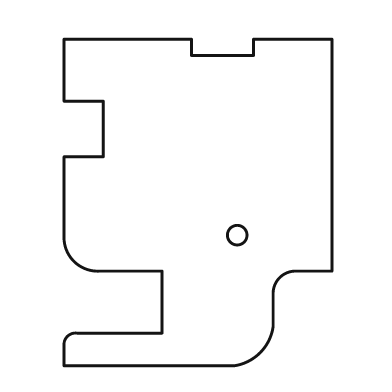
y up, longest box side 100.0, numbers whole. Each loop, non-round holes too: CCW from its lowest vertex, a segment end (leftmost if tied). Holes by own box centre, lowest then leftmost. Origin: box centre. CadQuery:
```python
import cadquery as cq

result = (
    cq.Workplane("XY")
    .moveTo(-41.0, -50.0)
    .lineTo(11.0, -50.0)
    .threePointArc((19.0, -46.0), (23.0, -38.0))
    .lineTo(23.0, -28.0)
    .threePointArc((25.0, -23.0), (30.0, -21.0))
    .lineTo(41.0, -21.0)
    .lineTo(41.0, 50.0)
    .lineTo(17.0, 50.0)
    .lineTo(17.0, 45.0)
    .lineTo(-2.0, 45.0)
    .lineTo(-2.0, 50.0)
    .lineTo(-41.0, 50.0)
    .lineTo(-41.0, 31.0)
    .lineTo(-29.0, 31.0)
    .lineTo(-29.0, 14.0)
    .lineTo(-41.0, 14.0)
    .lineTo(-41.0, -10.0)
    .threePointArc((-38.0, -18.0), (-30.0, -21.0))
    .lineTo(-11.0, -21.0)
    .lineTo(-11.0, -40.0)
    .lineTo(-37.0, -40.0)
    .threePointArc((-40.0, -41.0), (-41.0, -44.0))
    .close()
    .moveTo(12.0, -10.0)
    .circle(3.0)
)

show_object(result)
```